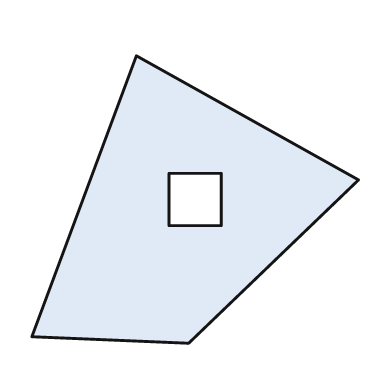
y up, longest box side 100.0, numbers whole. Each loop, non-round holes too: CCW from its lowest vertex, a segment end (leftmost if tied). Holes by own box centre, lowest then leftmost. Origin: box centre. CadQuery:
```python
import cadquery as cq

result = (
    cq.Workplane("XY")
    .moveTo(-2.0, -44.0)
    .lineTo(50.0, 6.0)
    .lineTo(-18.0, 44.0)
    .lineTo(-50.0, -42.0)
    .close()
    .moveTo(-8.0, -8.0)
    .lineTo(8.0, -8.0)
    .lineTo(8.0, 8.0)
    .lineTo(-8.0, 8.0)
    .close()
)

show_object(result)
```